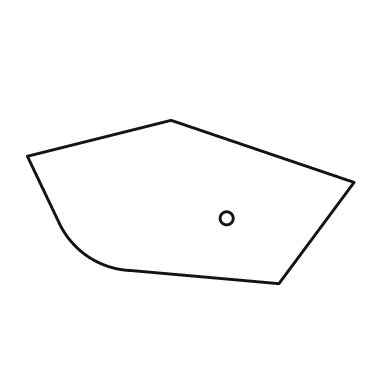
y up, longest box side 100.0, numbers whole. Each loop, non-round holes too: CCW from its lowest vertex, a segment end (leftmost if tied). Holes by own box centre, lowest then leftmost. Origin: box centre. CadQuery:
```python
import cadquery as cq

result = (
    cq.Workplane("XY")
    .moveTo(27.0, -25.0)
    .lineTo(50.0, 6.0)
    .lineTo(-6.0, 25.0)
    .lineTo(-50.0, 14.0)
    .lineTo(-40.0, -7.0)
    .threePointArc((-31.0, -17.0), (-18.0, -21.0))
    .close()
    .moveTo(11.0, -5.0)
    .circle(2.0)
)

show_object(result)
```